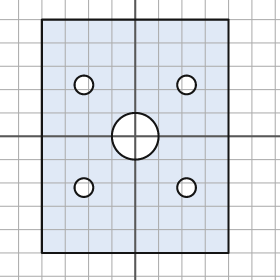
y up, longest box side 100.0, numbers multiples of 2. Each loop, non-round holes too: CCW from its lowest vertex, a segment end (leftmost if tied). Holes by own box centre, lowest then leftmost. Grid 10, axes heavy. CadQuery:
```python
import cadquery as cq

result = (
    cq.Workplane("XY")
    .moveTo(-40.0, -50.0)
    .lineTo(40.0, -50.0)
    .lineTo(40.0, 50.0)
    .lineTo(-40.0, 50.0)
    .close()
    .moveTo(-22.0, -22.0)
    .circle(4.0)
    .moveTo(22.0, -22.0)
    .circle(4.0)
    .moveTo(0.0, 0.0)
    .circle(10.0)
    .moveTo(-22.0, 22.0)
    .circle(4.0)
    .moveTo(22.0, 22.0)
    .circle(4.0)
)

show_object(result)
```